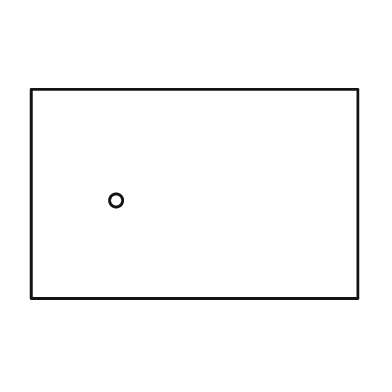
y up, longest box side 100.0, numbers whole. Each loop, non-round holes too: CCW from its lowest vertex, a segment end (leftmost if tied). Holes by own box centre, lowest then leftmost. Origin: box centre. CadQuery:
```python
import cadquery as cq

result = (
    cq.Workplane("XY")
    .moveTo(-50.0, -32.0)
    .lineTo(50.0, -32.0)
    .lineTo(50.0, 32.0)
    .lineTo(-50.0, 32.0)
    .close()
    .moveTo(-24.0, -2.0)
    .circle(2.0)
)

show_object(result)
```